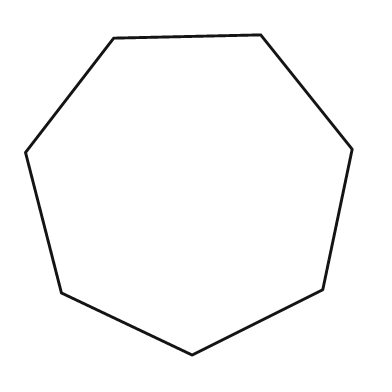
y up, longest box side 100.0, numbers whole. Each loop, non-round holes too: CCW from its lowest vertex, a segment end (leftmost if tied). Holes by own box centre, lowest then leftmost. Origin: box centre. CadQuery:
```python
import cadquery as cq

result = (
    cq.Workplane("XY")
    .moveTo(1.0, -49.0)
    .lineTo(41.0, -29.0)
    .lineTo(50.0, 14.0)
    .lineTo(22.0, 49.0)
    .lineTo(-23.0, 48.0)
    .lineTo(-50.0, 13.0)
    .lineTo(-39.0, -30.0)
    .close()
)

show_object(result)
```